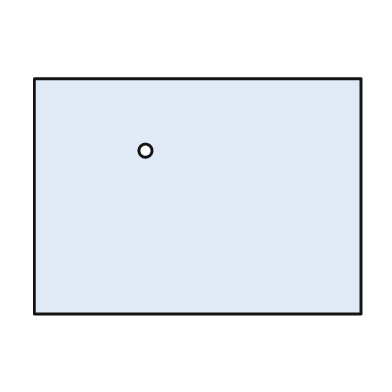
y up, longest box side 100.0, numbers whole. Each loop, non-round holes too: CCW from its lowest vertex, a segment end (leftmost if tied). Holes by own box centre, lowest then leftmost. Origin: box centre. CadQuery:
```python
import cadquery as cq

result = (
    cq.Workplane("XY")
    .moveTo(-50.0, -36.0)
    .lineTo(50.0, -36.0)
    .lineTo(50.0, 36.0)
    .lineTo(-50.0, 36.0)
    .close()
    .moveTo(-16.0, 14.0)
    .circle(2.0)
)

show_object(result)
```